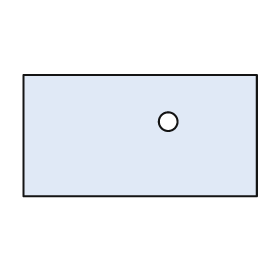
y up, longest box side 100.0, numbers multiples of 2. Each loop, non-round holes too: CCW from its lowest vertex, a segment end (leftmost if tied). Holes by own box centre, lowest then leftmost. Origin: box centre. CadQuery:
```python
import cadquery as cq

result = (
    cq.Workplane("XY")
    .moveTo(-50.0, -26.0)
    .lineTo(50.0, -26.0)
    .lineTo(50.0, 26.0)
    .lineTo(-50.0, 26.0)
    .close()
    .moveTo(12.0, 6.0)
    .circle(4.0)
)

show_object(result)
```